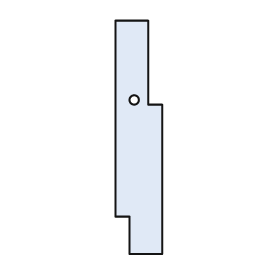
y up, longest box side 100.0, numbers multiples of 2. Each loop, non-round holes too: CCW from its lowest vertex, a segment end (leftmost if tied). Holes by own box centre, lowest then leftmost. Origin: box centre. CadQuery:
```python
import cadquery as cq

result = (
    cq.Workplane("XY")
    .moveTo(-4.0, -50.0)
    .lineTo(10.0, -50.0)
    .lineTo(10.0, 14.0)
    .lineTo(4.0, 14.0)
    .lineTo(4.0, 50.0)
    .lineTo(-10.0, 50.0)
    .lineTo(-10.0, -34.0)
    .lineTo(-4.0, -34.0)
    .close()
    .moveTo(-2.0, 16.0)
    .circle(2.0)
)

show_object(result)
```